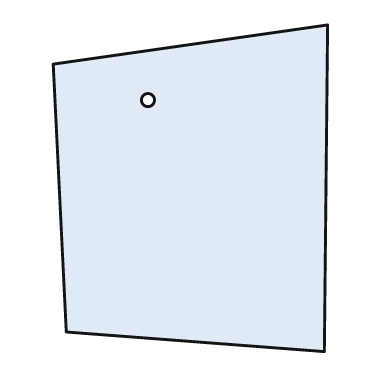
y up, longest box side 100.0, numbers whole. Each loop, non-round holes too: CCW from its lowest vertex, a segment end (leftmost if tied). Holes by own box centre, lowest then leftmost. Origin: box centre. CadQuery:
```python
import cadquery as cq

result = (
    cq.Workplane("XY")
    .moveTo(41.0, -50.0)
    .lineTo(42.0, 50.0)
    .lineTo(-42.0, 38.0)
    .lineTo(-38.0, -44.0)
    .close()
    .moveTo(-13.0, 27.0)
    .circle(2.0)
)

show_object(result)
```